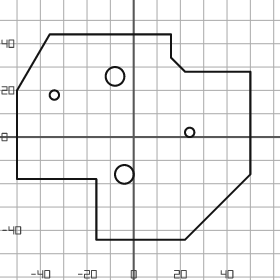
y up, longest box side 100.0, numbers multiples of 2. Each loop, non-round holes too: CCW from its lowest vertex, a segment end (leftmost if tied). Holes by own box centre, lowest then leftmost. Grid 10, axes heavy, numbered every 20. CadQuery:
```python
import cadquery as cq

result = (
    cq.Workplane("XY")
    .moveTo(-16.0, -44.0)
    .lineTo(22.0, -44.0)
    .lineTo(50.0, -16.0)
    .lineTo(50.0, 28.0)
    .lineTo(22.0, 28.0)
    .lineTo(16.0, 34.0)
    .lineTo(16.0, 44.0)
    .lineTo(-36.0, 44.0)
    .lineTo(-50.0, 20.0)
    .lineTo(-50.0, -18.0)
    .lineTo(-16.0, -18.0)
    .close()
    .moveTo(-4.0, -16.0)
    .circle(4.0)
    .moveTo(24.0, 2.0)
    .circle(2.0)
    .moveTo(-34.0, 18.0)
    .circle(2.0)
    .moveTo(-8.0, 26.0)
    .circle(4.0)
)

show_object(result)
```